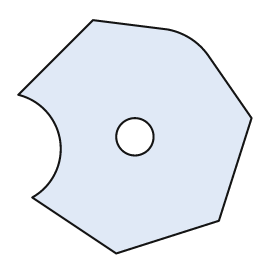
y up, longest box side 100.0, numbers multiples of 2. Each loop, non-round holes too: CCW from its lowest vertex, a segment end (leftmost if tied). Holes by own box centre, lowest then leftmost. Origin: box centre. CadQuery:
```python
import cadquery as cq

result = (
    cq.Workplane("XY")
    .moveTo(-8.0, -50.0)
    .lineTo(36.0, -36.0)
    .lineTo(50.0, 8.0)
    .lineTo(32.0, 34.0)
    .threePointArc((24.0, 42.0), (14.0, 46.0))
    .lineTo(-18.0, 50.0)
    .lineTo(-50.0, 18.0)
    .threePointArc((-32.0, -2.0), (-44.0, -26.0))
    .close()
    .moveTo(0.0, 0.0)
    .circle(8.0)
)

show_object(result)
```